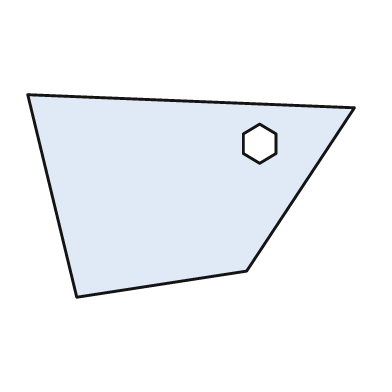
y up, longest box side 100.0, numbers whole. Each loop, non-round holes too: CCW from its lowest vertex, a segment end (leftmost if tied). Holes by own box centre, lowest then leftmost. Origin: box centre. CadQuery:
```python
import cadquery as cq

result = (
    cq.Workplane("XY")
    .moveTo(-35.0, -31.0)
    .lineTo(17.0, -23.0)
    .lineTo(50.0, 27.0)
    .lineTo(-50.0, 31.0)
    .close()
    .moveTo(21.0, 10.0)
    .lineTo(26.0, 13.0)
    .lineTo(26.0, 19.0)
    .lineTo(21.0, 22.0)
    .lineTo(16.0, 19.0)
    .lineTo(16.0, 13.0)
    .close()
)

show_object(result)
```